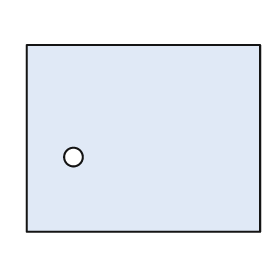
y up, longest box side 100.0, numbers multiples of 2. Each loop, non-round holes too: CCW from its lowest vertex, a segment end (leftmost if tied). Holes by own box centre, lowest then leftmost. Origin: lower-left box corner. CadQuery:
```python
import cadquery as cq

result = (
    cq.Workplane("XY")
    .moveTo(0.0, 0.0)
    .lineTo(100.0, 0.0)
    .lineTo(100.0, 80.0)
    .lineTo(0.0, 80.0)
    .close()
    .moveTo(20.0, 32.0)
    .circle(4.0)
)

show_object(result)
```